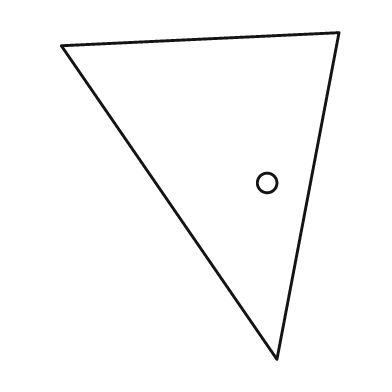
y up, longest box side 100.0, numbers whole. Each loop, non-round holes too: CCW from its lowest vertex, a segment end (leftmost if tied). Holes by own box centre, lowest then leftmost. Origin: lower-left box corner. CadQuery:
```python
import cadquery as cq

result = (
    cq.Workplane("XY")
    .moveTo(66.0, 0.0)
    .lineTo(85.0, 100.0)
    .lineTo(0.0, 96.0)
    .close()
    .moveTo(63.0, 54.0)
    .circle(3.0)
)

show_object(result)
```